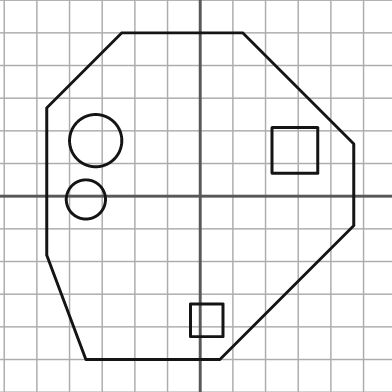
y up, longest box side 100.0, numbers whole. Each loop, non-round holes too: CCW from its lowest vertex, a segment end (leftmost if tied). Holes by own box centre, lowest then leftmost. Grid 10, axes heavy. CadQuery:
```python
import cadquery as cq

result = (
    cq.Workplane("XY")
    .moveTo(-35.0, -50.0)
    .lineTo(6.0, -50.0)
    .lineTo(47.0, -9.0)
    .lineTo(47.0, 16.0)
    .lineTo(13.0, 50.0)
    .lineTo(-24.0, 50.0)
    .lineTo(-47.0, 27.0)
    .lineTo(-47.0, -18.0)
    .close()
    .moveTo(-3.0, -43.0)
    .lineTo(7.0, -43.0)
    .lineTo(7.0, -33.0)
    .lineTo(-3.0, -33.0)
    .close()
    .moveTo(-35.0, -1.0)
    .circle(6.0)
    .moveTo(22.0, 7.0)
    .lineTo(36.0, 7.0)
    .lineTo(36.0, 21.0)
    .lineTo(22.0, 21.0)
    .close()
    .moveTo(-32.0, 17.0)
    .circle(8.0)
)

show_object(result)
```